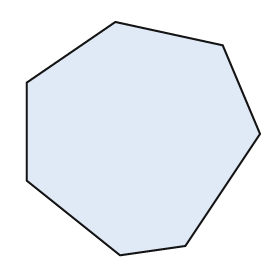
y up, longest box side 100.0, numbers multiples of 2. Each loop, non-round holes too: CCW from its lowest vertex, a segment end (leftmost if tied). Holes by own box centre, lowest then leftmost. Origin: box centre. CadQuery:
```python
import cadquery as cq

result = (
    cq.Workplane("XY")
    .moveTo(-10.0, -50.0)
    .lineTo(18.0, -46.0)
    .lineTo(50.0, 2.0)
    .lineTo(34.0, 40.0)
    .lineTo(-12.0, 50.0)
    .lineTo(-50.0, 24.0)
    .lineTo(-50.0, -18.0)
    .close()
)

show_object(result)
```